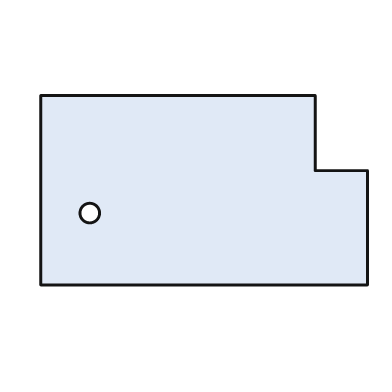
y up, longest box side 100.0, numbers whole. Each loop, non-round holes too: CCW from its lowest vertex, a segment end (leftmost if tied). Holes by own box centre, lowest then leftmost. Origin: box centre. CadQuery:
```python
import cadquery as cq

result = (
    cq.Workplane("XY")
    .moveTo(-50.0, -29.0)
    .lineTo(50.0, -29.0)
    .lineTo(50.0, 6.0)
    .lineTo(34.0, 6.0)
    .lineTo(34.0, 29.0)
    .lineTo(-50.0, 29.0)
    .close()
    .moveTo(-35.0, -7.0)
    .circle(3.0)
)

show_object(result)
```